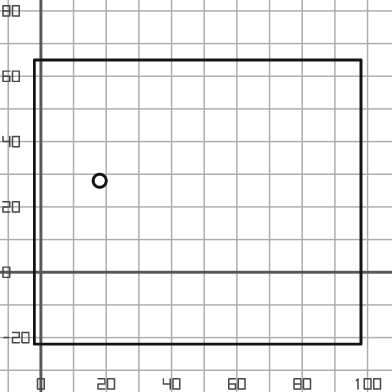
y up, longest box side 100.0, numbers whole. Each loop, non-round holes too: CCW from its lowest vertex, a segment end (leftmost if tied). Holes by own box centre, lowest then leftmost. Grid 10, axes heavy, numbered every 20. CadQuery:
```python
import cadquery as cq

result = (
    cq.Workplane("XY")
    .moveTo(-2.0, -22.0)
    .lineTo(98.0, -22.0)
    .lineTo(98.0, 65.0)
    .lineTo(-2.0, 65.0)
    .close()
    .moveTo(18.0, 28.0)
    .circle(2.0)
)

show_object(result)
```